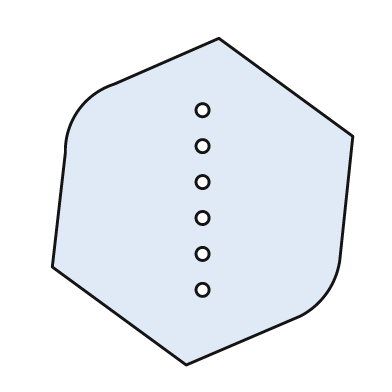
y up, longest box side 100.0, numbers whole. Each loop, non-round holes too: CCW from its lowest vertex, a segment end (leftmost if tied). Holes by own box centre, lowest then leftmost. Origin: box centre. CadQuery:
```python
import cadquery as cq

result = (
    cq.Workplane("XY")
    .moveTo(-5.0, -50.0)
    .lineTo(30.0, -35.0)
    .threePointArc((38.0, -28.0), (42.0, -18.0))
    .lineTo(46.0, 20.0)
    .lineTo(5.0, 50.0)
    .lineTo(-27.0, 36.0)
    .threePointArc((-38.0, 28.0), (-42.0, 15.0))
    .lineTo(-46.0, -20.0)
    .close()
    .moveTo(0.0, -27.0)
    .circle(2.0)
    .moveTo(0.0, -16.0)
    .circle(2.0)
    .moveTo(0.0, -5.0)
    .circle(2.0)
    .moveTo(0.0, 6.0)
    .circle(2.0)
    .moveTo(0.0, 17.0)
    .circle(2.0)
    .moveTo(0.0, 28.0)
    .circle(2.0)
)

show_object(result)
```